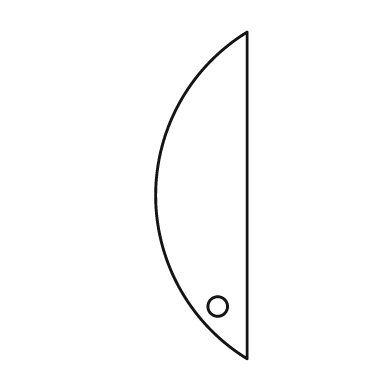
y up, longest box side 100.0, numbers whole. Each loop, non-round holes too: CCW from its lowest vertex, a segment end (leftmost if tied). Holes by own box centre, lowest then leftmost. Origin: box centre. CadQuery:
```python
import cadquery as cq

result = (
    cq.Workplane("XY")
    .moveTo(14.0, -50.0)
    .lineTo(14.0, 50.0)
    .threePointArc((-14.0, 0.0), (14.0, -50.0))
    .close()
    .moveTo(5.0, -34.0)
    .circle(3.0)
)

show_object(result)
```